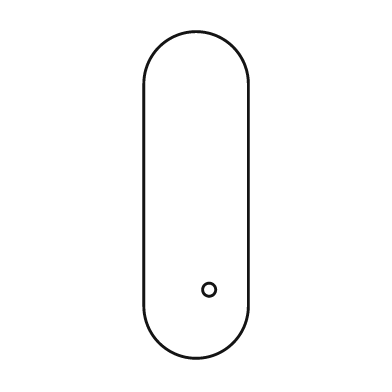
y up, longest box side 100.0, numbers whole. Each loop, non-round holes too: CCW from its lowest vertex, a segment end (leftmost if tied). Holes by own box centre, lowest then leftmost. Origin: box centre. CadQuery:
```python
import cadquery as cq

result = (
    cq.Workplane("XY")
    .moveTo(-16.0, -34.0)
    .threePointArc((0.0, -50.0), (16.0, -34.0))
    .lineTo(16.0, 34.0)
    .threePointArc((0.0, 50.0), (-16.0, 34.0))
    .close()
    .moveTo(4.0, -29.0)
    .circle(2.0)
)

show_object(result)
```